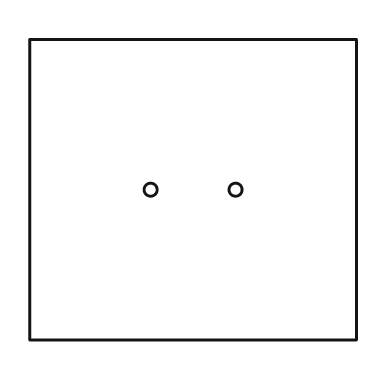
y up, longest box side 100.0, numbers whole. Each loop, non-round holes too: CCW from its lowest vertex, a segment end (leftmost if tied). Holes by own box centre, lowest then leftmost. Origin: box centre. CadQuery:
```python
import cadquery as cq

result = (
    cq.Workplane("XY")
    .moveTo(-50.0, -46.0)
    .lineTo(50.0, -46.0)
    .lineTo(50.0, 46.0)
    .lineTo(-50.0, 46.0)
    .close()
    .moveTo(-13.0, 0.0)
    .circle(2.0)
    .moveTo(13.0, 0.0)
    .circle(2.0)
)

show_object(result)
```